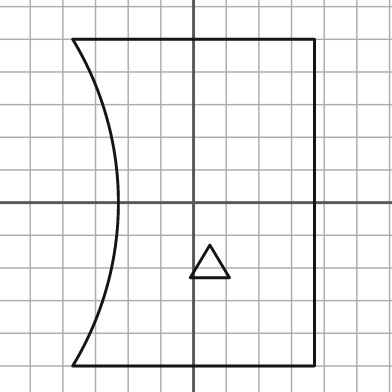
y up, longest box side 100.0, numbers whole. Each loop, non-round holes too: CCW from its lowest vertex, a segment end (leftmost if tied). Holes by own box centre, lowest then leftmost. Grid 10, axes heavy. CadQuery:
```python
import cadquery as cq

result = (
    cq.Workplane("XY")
    .moveTo(-37.0, -50.0)
    .lineTo(37.0, -50.0)
    .lineTo(37.0, 50.0)
    .lineTo(-37.0, 50.0)
    .threePointArc((-23.0, 0.0), (-37.0, -50.0))
    .close()
    .moveTo(-1.0, -23.0)
    .lineTo(11.0, -23.0)
    .lineTo(5.0, -13.0)
    .close()
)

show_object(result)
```